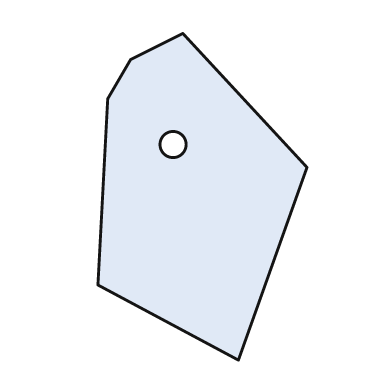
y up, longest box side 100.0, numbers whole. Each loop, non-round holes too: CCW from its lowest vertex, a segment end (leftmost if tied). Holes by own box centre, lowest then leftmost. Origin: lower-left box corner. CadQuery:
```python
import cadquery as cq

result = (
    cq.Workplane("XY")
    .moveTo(43.0, 0.0)
    .lineTo(64.0, 59.0)
    .lineTo(26.0, 100.0)
    .lineTo(10.0, 92.0)
    .lineTo(3.0, 80.0)
    .lineTo(0.0, 23.0)
    .close()
    .moveTo(23.0, 66.0)
    .circle(4.0)
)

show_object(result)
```